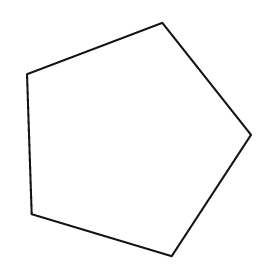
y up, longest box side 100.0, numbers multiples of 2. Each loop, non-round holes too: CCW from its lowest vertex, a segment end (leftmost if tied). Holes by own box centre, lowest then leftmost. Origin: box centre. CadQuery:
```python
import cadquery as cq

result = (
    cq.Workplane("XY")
    .moveTo(14.0, -50.0)
    .lineTo(48.0, 2.0)
    .lineTo(10.0, 50.0)
    .lineTo(-48.0, 28.0)
    .lineTo(-46.0, -32.0)
    .close()
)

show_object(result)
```